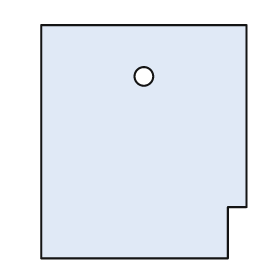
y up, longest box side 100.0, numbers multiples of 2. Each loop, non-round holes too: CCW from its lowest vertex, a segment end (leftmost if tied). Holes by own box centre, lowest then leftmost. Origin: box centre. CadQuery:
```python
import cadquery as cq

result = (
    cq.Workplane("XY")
    .moveTo(-44.0, -50.0)
    .lineTo(36.0, -50.0)
    .lineTo(36.0, -28.0)
    .lineTo(44.0, -28.0)
    .lineTo(44.0, 50.0)
    .lineTo(-44.0, 50.0)
    .close()
    .moveTo(0.0, 28.0)
    .circle(4.0)
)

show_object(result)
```